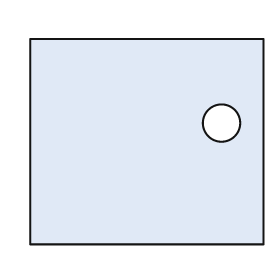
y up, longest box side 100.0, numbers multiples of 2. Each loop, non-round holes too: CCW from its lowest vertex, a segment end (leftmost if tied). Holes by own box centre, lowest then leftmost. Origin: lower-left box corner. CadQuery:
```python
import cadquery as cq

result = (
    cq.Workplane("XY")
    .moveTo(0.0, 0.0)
    .lineTo(100.0, 0.0)
    .lineTo(100.0, 88.0)
    .lineTo(0.0, 88.0)
    .close()
    .moveTo(82.0, 52.0)
    .circle(8.0)
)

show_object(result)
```